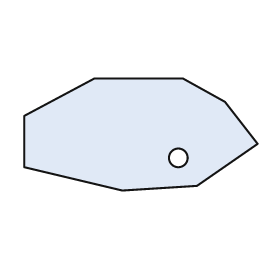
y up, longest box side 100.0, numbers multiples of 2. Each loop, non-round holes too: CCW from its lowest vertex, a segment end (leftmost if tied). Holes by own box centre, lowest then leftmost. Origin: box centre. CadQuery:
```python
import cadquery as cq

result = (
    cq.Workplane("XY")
    .moveTo(-8.0, -24.0)
    .lineTo(24.0, -22.0)
    .lineTo(50.0, -4.0)
    .lineTo(36.0, 14.0)
    .lineTo(18.0, 24.0)
    .lineTo(-20.0, 24.0)
    .lineTo(-50.0, 8.0)
    .lineTo(-50.0, -14.0)
    .close()
    .moveTo(16.0, -10.0)
    .circle(4.0)
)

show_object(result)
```